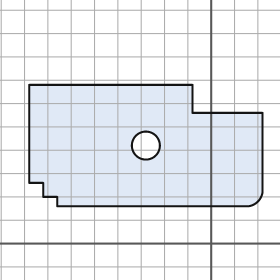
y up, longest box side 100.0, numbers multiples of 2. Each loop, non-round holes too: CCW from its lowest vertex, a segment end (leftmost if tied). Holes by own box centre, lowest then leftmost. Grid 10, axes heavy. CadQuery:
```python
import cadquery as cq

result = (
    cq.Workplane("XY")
    .moveTo(-66.0, 16.0)
    .lineTo(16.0, 16.0)
    .threePointArc((20.0, 18.0), (22.0, 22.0))
    .lineTo(22.0, 56.0)
    .lineTo(-8.0, 56.0)
    .lineTo(-8.0, 68.0)
    .lineTo(-78.0, 68.0)
    .lineTo(-78.0, 26.0)
    .lineTo(-72.0, 26.0)
    .lineTo(-72.0, 20.0)
    .lineTo(-66.0, 20.0)
    .close()
    .moveTo(-28.0, 42.0)
    .circle(6.0)
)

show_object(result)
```